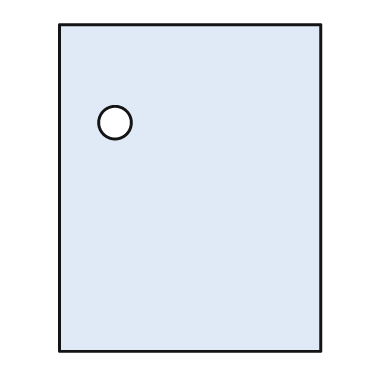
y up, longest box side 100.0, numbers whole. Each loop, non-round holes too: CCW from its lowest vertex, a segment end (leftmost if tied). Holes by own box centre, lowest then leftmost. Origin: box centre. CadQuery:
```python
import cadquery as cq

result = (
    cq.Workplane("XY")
    .moveTo(-40.0, -50.0)
    .lineTo(40.0, -50.0)
    .lineTo(40.0, 50.0)
    .lineTo(-40.0, 50.0)
    .close()
    .moveTo(-23.0, 20.0)
    .circle(5.0)
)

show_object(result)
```